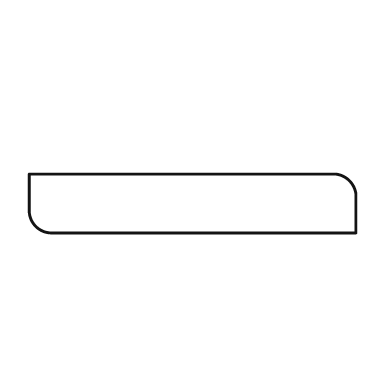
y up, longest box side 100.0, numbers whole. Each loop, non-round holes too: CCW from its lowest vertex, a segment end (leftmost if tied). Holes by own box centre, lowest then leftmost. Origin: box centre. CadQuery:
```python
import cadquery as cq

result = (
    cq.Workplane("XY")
    .moveTo(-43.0, -9.0)
    .lineTo(50.0, -9.0)
    .lineTo(50.0, 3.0)
    .threePointArc((48.0, 7.0), (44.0, 9.0))
    .lineTo(-50.0, 9.0)
    .lineTo(-50.0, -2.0)
    .threePointArc((-48.0, -7.0), (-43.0, -9.0))
    .close()
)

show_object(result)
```